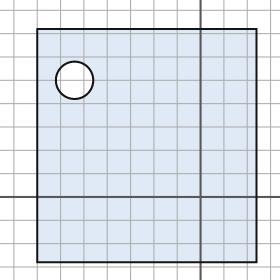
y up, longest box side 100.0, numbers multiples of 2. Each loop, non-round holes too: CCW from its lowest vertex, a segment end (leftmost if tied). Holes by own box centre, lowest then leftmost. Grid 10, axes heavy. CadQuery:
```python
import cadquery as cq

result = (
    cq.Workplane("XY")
    .moveTo(-70.0, -28.0)
    .lineTo(24.0, -28.0)
    .lineTo(24.0, 72.0)
    .lineTo(-70.0, 72.0)
    .close()
    .moveTo(-54.0, 50.0)
    .circle(8.0)
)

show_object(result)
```